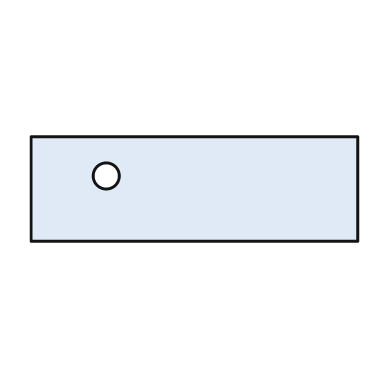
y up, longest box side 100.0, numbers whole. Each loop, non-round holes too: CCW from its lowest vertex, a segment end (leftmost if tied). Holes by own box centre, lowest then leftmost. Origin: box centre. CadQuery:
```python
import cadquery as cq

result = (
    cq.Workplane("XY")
    .moveTo(-50.0, -16.0)
    .lineTo(50.0, -16.0)
    .lineTo(50.0, 16.0)
    .lineTo(-50.0, 16.0)
    .close()
    .moveTo(-27.0, 4.0)
    .circle(4.0)
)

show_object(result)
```